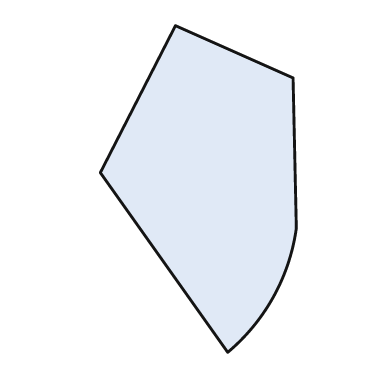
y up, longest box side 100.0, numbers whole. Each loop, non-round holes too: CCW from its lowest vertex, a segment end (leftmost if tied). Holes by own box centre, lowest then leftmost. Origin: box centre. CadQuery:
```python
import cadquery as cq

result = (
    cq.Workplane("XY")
    .moveTo(9.0, -50.0)
    .threePointArc((23.0, -33.0), (30.0, -12.0))
    .lineTo(29.0, 34.0)
    .lineTo(-7.0, 50.0)
    .lineTo(-30.0, 5.0)
    .close()
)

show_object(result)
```